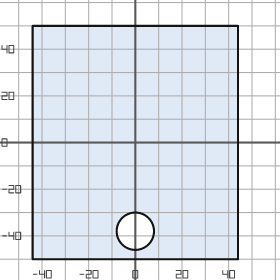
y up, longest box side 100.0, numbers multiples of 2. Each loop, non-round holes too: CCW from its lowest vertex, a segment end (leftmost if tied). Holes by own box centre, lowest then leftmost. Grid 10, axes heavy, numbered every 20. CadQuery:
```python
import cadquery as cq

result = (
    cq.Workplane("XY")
    .moveTo(-44.0, -50.0)
    .lineTo(44.0, -50.0)
    .lineTo(44.0, 50.0)
    .lineTo(-44.0, 50.0)
    .close()
    .moveTo(0.0, -38.0)
    .circle(8.0)
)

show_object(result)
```